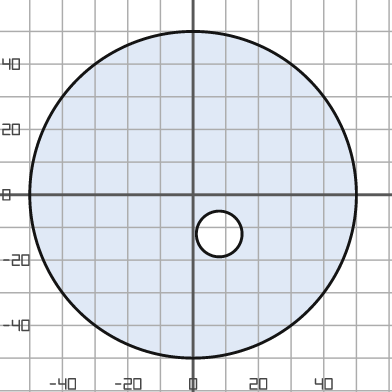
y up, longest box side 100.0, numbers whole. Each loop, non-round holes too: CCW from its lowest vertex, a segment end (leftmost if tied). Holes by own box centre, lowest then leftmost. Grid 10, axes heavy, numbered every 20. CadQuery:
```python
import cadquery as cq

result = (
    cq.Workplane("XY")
    .moveTo(0.0, 0.0)
    .circle(50.0)
    .moveTo(8.0, -12.0)
    .circle(7.0)
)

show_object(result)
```